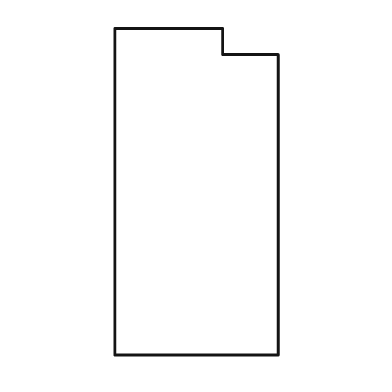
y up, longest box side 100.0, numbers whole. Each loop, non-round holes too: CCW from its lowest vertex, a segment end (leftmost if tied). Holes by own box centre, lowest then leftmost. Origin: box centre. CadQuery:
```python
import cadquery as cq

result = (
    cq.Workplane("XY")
    .moveTo(-25.0, -50.0)
    .lineTo(25.0, -50.0)
    .lineTo(25.0, 42.0)
    .lineTo(8.0, 42.0)
    .lineTo(8.0, 50.0)
    .lineTo(-25.0, 50.0)
    .close()
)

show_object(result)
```